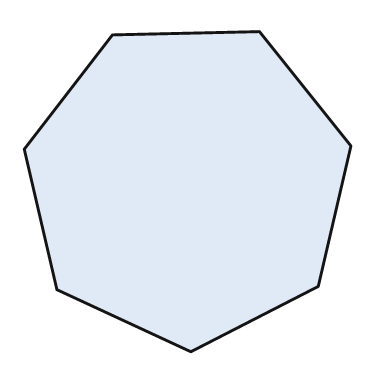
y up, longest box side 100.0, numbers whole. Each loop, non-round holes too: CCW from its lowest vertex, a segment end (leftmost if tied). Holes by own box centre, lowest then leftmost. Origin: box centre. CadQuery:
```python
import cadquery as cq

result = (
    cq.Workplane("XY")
    .moveTo(1.0, -49.0)
    .lineTo(40.0, -29.0)
    .lineTo(50.0, 14.0)
    .lineTo(22.0, 49.0)
    .lineTo(-23.0, 48.0)
    .lineTo(-50.0, 13.0)
    .lineTo(-40.0, -30.0)
    .close()
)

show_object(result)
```